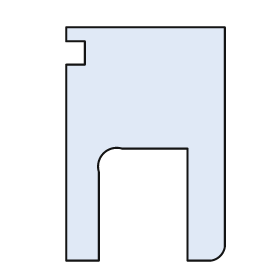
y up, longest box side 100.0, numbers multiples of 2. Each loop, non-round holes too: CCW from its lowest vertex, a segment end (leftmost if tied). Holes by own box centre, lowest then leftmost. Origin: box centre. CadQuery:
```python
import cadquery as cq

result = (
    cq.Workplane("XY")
    .moveTo(-34.0, -50.0)
    .lineTo(-20.0, -50.0)
    .lineTo(-20.0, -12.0)
    .threePointArc((-18.0, -4.0), (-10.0, -2.0))
    .lineTo(18.0, -2.0)
    .lineTo(18.0, -50.0)
    .lineTo(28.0, -50.0)
    .threePointArc((32.0, -48.0), (34.0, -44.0))
    .lineTo(34.0, 50.0)
    .lineTo(-34.0, 50.0)
    .lineTo(-34.0, 44.0)
    .lineTo(-26.0, 44.0)
    .lineTo(-26.0, 34.0)
    .lineTo(-34.0, 34.0)
    .close()
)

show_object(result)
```